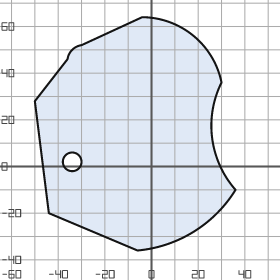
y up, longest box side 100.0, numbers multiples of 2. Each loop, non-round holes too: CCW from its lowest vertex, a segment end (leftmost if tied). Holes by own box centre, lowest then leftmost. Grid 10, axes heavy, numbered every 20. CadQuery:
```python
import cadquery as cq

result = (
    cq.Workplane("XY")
    .moveTo(-6.0, -36.0)
    .threePointArc((18.0, -28.0), (36.0, -10.0))
    .threePointArc((26.0, 12.0), (30.0, 36.0))
    .threePointArc((18.0, 56.0), (-4.0, 64.0))
    .lineTo(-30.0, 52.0)
    .threePointArc((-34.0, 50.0), (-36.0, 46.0))
    .lineTo(-50.0, 28.0)
    .lineTo(-44.0, -20.0)
    .close()
    .moveTo(-34.0, 2.0)
    .circle(4.0)
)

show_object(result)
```